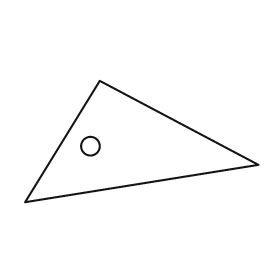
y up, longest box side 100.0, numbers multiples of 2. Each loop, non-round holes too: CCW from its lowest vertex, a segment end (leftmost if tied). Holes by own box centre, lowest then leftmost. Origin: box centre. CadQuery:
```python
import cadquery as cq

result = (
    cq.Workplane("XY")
    .moveTo(-50.0, -26.0)
    .lineTo(50.0, -10.0)
    .lineTo(-18.0, 26.0)
    .close()
    .moveTo(-22.0, -2.0)
    .circle(4.0)
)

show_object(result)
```